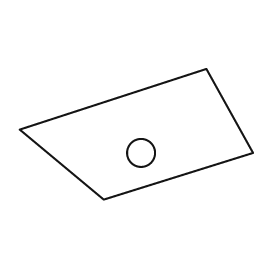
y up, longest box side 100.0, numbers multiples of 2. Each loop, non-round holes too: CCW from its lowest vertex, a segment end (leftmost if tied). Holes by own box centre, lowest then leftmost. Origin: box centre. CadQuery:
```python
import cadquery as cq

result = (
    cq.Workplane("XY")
    .moveTo(-14.0, -28.0)
    .lineTo(50.0, -8.0)
    .lineTo(30.0, 28.0)
    .lineTo(-50.0, 2.0)
    .close()
    .moveTo(2.0, -8.0)
    .circle(6.0)
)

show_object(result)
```